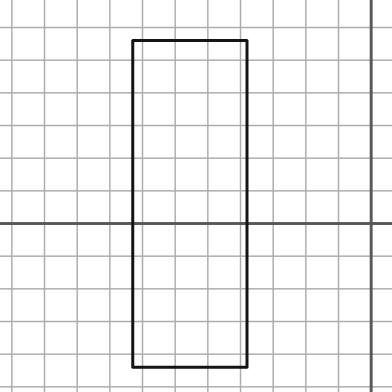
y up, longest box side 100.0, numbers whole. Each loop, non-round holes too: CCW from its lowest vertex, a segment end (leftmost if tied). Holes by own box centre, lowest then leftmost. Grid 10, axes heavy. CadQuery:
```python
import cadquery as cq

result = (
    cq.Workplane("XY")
    .moveTo(-73.0, -44.0)
    .lineTo(-38.0, -44.0)
    .lineTo(-38.0, 56.0)
    .lineTo(-73.0, 56.0)
    .close()
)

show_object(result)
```